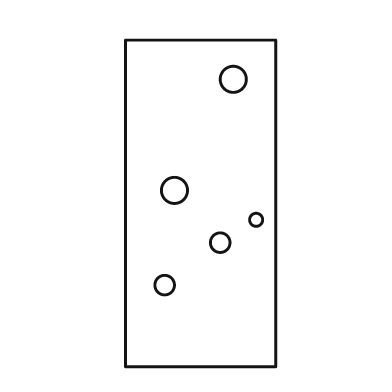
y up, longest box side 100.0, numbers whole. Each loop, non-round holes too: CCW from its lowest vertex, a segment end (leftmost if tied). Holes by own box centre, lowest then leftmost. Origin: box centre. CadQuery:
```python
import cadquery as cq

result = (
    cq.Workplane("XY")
    .moveTo(-23.0, -50.0)
    .lineTo(23.0, -50.0)
    .lineTo(23.0, 50.0)
    .lineTo(-23.0, 50.0)
    .close()
    .moveTo(-11.0, -25.0)
    .circle(3.0)
    .moveTo(6.0, -12.0)
    .circle(3.0)
    .moveTo(17.0, -5.0)
    .circle(2.0)
    .moveTo(-8.0, 4.0)
    .circle(4.0)
    .moveTo(10.0, 38.0)
    .circle(4.0)
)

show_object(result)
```